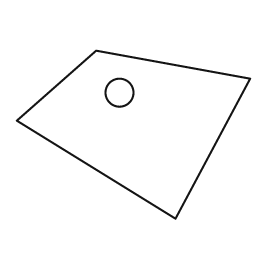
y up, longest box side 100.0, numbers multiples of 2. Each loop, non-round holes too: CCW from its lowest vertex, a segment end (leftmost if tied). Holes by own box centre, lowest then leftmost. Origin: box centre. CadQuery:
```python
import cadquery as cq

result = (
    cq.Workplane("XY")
    .moveTo(18.0, -36.0)
    .lineTo(50.0, 24.0)
    .lineTo(-16.0, 36.0)
    .lineTo(-50.0, 6.0)
    .close()
    .moveTo(-6.0, 18.0)
    .circle(6.0)
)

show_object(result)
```